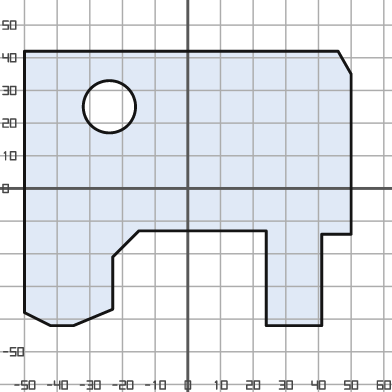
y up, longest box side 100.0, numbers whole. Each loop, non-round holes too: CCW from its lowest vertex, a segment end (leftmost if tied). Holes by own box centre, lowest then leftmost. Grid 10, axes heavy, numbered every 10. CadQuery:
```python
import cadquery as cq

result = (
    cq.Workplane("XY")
    .moveTo(-42.0, -42.0)
    .lineTo(-35.0, -42.0)
    .lineTo(-23.0, -37.0)
    .lineTo(-23.0, -21.0)
    .lineTo(-15.0, -13.0)
    .lineTo(24.0, -13.0)
    .lineTo(24.0, -42.0)
    .lineTo(41.0, -42.0)
    .lineTo(41.0, -14.0)
    .lineTo(50.0, -14.0)
    .lineTo(50.0, 35.0)
    .lineTo(46.0, 42.0)
    .lineTo(-50.0, 42.0)
    .lineTo(-50.0, -38.0)
    .close()
    .moveTo(-24.0, 25.0)
    .circle(8.0)
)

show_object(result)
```